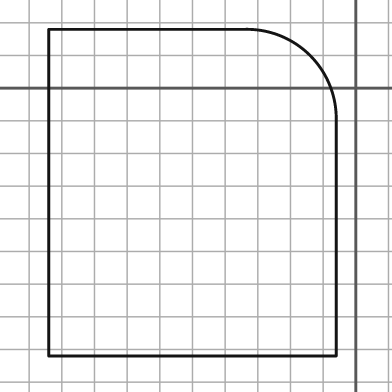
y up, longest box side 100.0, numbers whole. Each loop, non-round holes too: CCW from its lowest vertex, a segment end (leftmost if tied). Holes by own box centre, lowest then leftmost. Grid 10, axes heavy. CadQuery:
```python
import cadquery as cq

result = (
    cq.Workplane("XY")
    .moveTo(-94.0, -82.0)
    .lineTo(-6.0, -82.0)
    .lineTo(-6.0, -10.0)
    .threePointArc((-14.0, 10.0), (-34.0, 18.0))
    .lineTo(-94.0, 18.0)
    .close()
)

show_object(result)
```